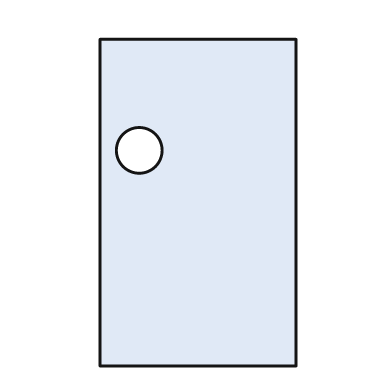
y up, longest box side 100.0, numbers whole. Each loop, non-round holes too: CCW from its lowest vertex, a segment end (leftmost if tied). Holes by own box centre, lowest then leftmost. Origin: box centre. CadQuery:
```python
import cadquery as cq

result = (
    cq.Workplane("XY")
    .moveTo(-30.0, -50.0)
    .lineTo(30.0, -50.0)
    .lineTo(30.0, 50.0)
    .lineTo(-30.0, 50.0)
    .close()
    .moveTo(-18.0, 16.0)
    .circle(7.0)
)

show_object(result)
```